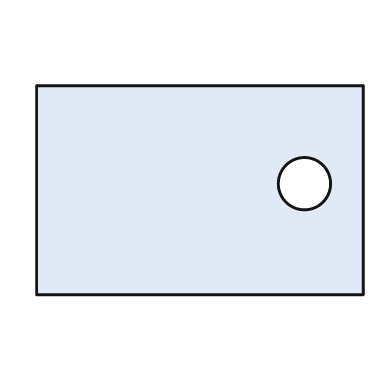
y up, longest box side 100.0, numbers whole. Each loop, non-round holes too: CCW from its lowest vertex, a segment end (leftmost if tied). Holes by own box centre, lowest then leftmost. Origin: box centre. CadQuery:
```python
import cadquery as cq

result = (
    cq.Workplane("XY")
    .moveTo(-50.0, -32.0)
    .lineTo(50.0, -32.0)
    .lineTo(50.0, 32.0)
    .lineTo(-50.0, 32.0)
    .close()
    .moveTo(32.0, 2.0)
    .circle(8.0)
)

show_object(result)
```